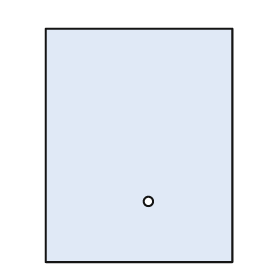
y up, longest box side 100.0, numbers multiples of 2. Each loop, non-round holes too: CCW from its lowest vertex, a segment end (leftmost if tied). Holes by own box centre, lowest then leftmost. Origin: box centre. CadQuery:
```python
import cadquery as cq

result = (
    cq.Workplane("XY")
    .moveTo(-40.0, -50.0)
    .lineTo(40.0, -50.0)
    .lineTo(40.0, 50.0)
    .lineTo(-40.0, 50.0)
    .close()
    .moveTo(4.0, -24.0)
    .circle(2.0)
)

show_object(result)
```